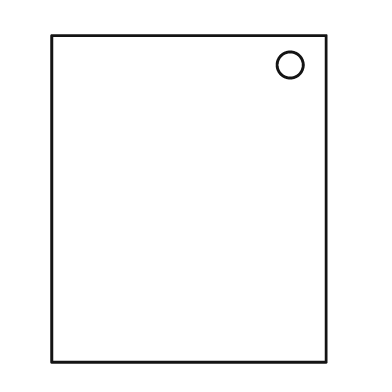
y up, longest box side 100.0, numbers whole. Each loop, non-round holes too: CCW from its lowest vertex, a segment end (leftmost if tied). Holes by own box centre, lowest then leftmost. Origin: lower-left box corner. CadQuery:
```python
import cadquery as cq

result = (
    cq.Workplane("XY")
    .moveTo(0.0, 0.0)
    .lineTo(84.0, 0.0)
    .lineTo(84.0, 100.0)
    .lineTo(0.0, 100.0)
    .close()
    .moveTo(73.0, 91.0)
    .circle(4.0)
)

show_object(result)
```